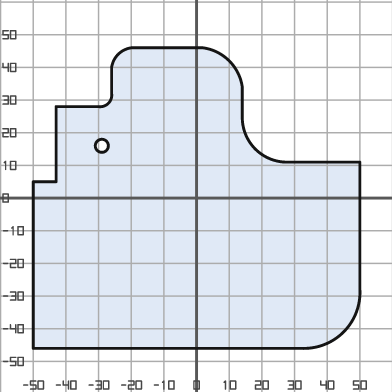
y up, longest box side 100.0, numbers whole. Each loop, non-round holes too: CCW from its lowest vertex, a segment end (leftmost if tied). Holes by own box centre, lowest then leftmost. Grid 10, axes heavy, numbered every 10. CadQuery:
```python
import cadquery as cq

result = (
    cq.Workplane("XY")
    .moveTo(-50.0, -46.0)
    .lineTo(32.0, -46.0)
    .threePointArc((45.0, -41.0), (50.0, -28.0))
    .lineTo(50.0, 11.0)
    .lineTo(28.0, 11.0)
    .threePointArc((18.0, 15.0), (14.0, 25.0))
    .lineTo(14.0, 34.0)
    .threePointArc((10.0, 42.0), (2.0, 46.0))
    .lineTo(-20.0, 46.0)
    .threePointArc((-24.0, 44.0), (-26.0, 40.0))
    .lineTo(-26.0, 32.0)
    .threePointArc((-27.0, 29.0), (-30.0, 28.0))
    .lineTo(-43.0, 28.0)
    .lineTo(-43.0, 5.0)
    .lineTo(-50.0, 5.0)
    .close()
    .moveTo(-29.0, 16.0)
    .circle(2.0)
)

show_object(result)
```